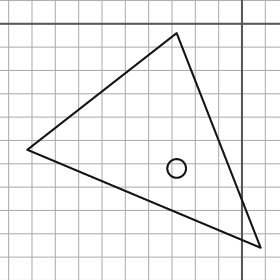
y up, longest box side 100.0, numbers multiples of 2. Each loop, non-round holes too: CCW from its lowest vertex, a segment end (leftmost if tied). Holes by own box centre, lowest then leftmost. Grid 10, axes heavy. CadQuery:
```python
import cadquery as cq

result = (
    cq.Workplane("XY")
    .moveTo(8.0, -96.0)
    .lineTo(-28.0, -4.0)
    .lineTo(-92.0, -54.0)
    .close()
    .moveTo(-28.0, -62.0)
    .circle(4.0)
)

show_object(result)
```